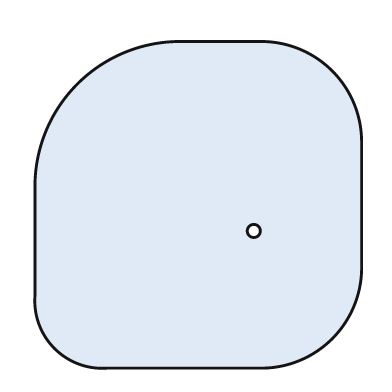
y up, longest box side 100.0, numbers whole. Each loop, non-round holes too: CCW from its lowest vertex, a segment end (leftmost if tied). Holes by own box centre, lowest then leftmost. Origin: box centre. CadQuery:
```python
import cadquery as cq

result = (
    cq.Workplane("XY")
    .moveTo(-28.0, -50.0)
    .lineTo(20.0, -50.0)
    .threePointArc((41.0, -41.0), (50.0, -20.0))
    .lineTo(50.0, 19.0)
    .threePointArc((41.0, 41.0), (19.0, 50.0))
    .lineTo(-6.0, 50.0)
    .threePointArc((-37.0, 37.0), (-50.0, 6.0))
    .lineTo(-50.0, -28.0)
    .threePointArc((-44.0, -44.0), (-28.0, -50.0))
    .close()
    .moveTo(17.0, -8.0)
    .circle(2.0)
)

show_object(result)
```